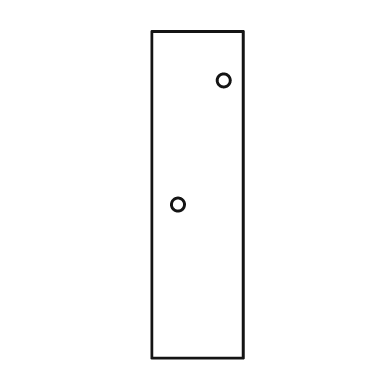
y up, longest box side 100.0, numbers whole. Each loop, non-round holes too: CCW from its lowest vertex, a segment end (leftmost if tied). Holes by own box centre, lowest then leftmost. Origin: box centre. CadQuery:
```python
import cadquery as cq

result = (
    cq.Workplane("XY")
    .moveTo(-14.0, -50.0)
    .lineTo(14.0, -50.0)
    .lineTo(14.0, 50.0)
    .lineTo(-14.0, 50.0)
    .close()
    .moveTo(-6.0, -3.0)
    .circle(2.0)
    .moveTo(8.0, 35.0)
    .circle(2.0)
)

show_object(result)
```